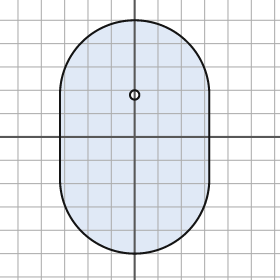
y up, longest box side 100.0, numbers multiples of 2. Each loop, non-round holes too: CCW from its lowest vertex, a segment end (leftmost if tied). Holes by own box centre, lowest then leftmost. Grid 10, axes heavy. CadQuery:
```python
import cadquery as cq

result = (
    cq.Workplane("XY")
    .moveTo(-32.0, -18.0)
    .threePointArc((0.0, -50.0), (32.0, -18.0))
    .lineTo(32.0, 18.0)
    .threePointArc((0.0, 50.0), (-32.0, 18.0))
    .close()
    .moveTo(0.0, 18.0)
    .circle(2.0)
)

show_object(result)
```